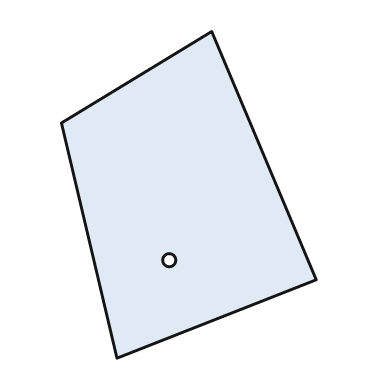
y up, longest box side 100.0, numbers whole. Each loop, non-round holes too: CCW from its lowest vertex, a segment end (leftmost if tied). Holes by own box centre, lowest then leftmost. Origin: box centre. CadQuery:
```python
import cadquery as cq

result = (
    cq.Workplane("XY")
    .moveTo(-22.0, -50.0)
    .lineTo(39.0, -26.0)
    .lineTo(7.0, 50.0)
    .lineTo(-39.0, 22.0)
    .close()
    .moveTo(-6.0, -20.0)
    .circle(2.0)
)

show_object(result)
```